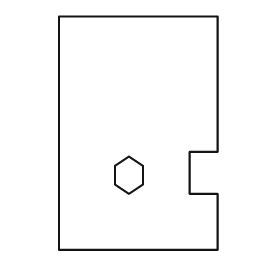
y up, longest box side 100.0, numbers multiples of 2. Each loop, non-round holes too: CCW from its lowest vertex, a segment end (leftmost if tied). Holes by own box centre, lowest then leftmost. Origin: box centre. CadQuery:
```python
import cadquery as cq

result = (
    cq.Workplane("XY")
    .moveTo(-34.0, -50.0)
    .lineTo(34.0, -50.0)
    .lineTo(34.0, -26.0)
    .lineTo(22.0, -26.0)
    .lineTo(22.0, -8.0)
    .lineTo(34.0, -8.0)
    .lineTo(34.0, 50.0)
    .lineTo(-34.0, 50.0)
    .close()
    .moveTo(-4.0, -26.0)
    .lineTo(2.0, -22.0)
    .lineTo(2.0, -14.0)
    .lineTo(-4.0, -10.0)
    .lineTo(-10.0, -14.0)
    .lineTo(-10.0, -22.0)
    .close()
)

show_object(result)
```